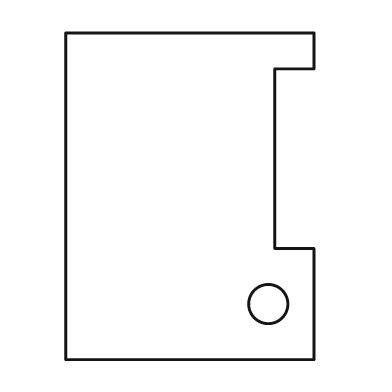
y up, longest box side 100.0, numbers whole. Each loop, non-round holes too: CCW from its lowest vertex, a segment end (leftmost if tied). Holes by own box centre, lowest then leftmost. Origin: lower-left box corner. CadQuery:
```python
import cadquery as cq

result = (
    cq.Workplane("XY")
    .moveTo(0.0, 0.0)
    .lineTo(76.0, 0.0)
    .lineTo(76.0, 34.0)
    .lineTo(64.0, 34.0)
    .lineTo(64.0, 89.0)
    .lineTo(76.0, 89.0)
    .lineTo(76.0, 100.0)
    .lineTo(0.0, 100.0)
    .close()
    .moveTo(62.0, 17.0)
    .circle(6.0)
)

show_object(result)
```